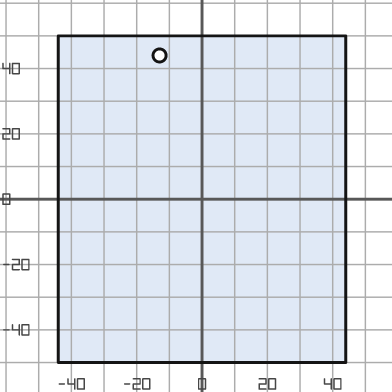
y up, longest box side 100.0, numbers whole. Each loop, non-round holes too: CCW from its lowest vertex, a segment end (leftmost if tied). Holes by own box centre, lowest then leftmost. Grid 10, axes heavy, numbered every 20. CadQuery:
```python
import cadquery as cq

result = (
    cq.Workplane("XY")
    .moveTo(-44.0, -50.0)
    .lineTo(44.0, -50.0)
    .lineTo(44.0, 50.0)
    .lineTo(-44.0, 50.0)
    .close()
    .moveTo(-13.0, 44.0)
    .circle(2.0)
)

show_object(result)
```